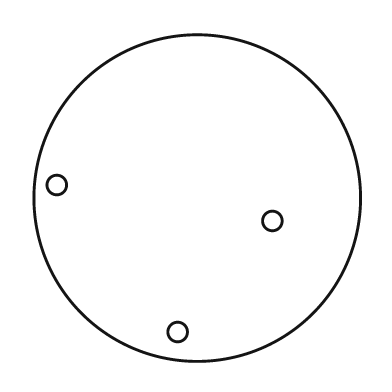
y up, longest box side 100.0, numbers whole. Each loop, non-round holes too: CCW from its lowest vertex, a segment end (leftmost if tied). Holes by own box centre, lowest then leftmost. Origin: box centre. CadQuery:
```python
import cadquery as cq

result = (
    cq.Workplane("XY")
    .moveTo(0.0, 0.0)
    .circle(50.0)
    .moveTo(-6.0, -41.0)
    .circle(3.0)
    .moveTo(23.0, -7.0)
    .circle(3.0)
    .moveTo(-43.0, 4.0)
    .circle(3.0)
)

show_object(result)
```